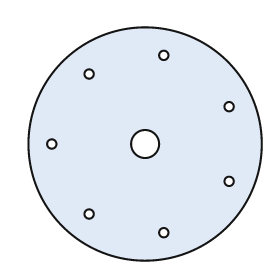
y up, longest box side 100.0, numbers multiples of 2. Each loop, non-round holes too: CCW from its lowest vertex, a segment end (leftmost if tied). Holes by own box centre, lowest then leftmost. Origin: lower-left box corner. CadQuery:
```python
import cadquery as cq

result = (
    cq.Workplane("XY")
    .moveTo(50.0, 50.0)
    .circle(50.0)
    .moveTo(58.0, 12.0)
    .circle(2.0)
    .moveTo(26.0, 20.0)
    .circle(2.0)
    .moveTo(86.0, 34.0)
    .circle(2.0)
    .moveTo(10.0, 50.0)
    .circle(2.0)
    .moveTo(50.0, 50.0)
    .circle(6.0)
    .moveTo(86.0, 66.0)
    .circle(2.0)
    .moveTo(26.0, 80.0)
    .circle(2.0)
    .moveTo(58.0, 88.0)
    .circle(2.0)
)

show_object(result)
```